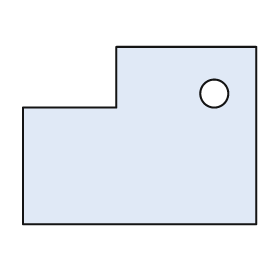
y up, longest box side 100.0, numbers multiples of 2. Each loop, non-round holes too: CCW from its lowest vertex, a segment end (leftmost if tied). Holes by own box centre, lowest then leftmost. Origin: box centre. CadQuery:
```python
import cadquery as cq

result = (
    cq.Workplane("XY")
    .moveTo(-50.0, -38.0)
    .lineTo(50.0, -38.0)
    .lineTo(50.0, 38.0)
    .lineTo(-10.0, 38.0)
    .lineTo(-10.0, 12.0)
    .lineTo(-50.0, 12.0)
    .close()
    .moveTo(32.0, 18.0)
    .circle(6.0)
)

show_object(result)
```